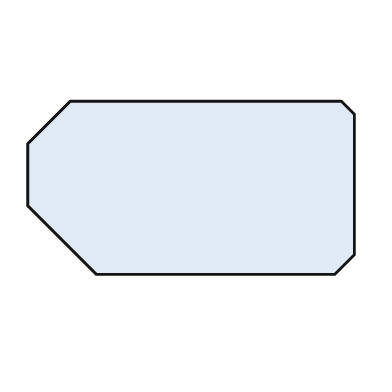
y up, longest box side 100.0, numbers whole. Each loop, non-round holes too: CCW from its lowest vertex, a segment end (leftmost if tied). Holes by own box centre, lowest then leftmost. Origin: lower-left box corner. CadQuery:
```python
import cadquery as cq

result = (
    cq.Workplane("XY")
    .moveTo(21.0, 0.0)
    .lineTo(94.0, 0.0)
    .lineTo(100.0, 6.0)
    .lineTo(100.0, 49.0)
    .lineTo(96.0, 53.0)
    .lineTo(13.0, 53.0)
    .lineTo(0.0, 40.0)
    .lineTo(0.0, 21.0)
    .close()
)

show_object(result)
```